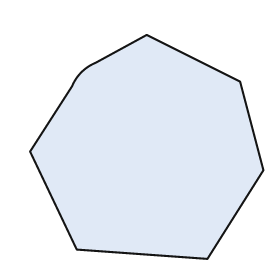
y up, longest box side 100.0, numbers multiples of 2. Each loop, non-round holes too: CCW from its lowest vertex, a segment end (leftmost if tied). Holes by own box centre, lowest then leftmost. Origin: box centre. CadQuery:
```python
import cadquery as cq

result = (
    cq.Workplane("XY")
    .moveTo(26.0, -48.0)
    .lineTo(50.0, -10.0)
    .lineTo(40.0, 28.0)
    .lineTo(0.0, 48.0)
    .lineTo(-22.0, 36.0)
    .threePointArc((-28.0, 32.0), (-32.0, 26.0))
    .lineTo(-50.0, -2.0)
    .lineTo(-30.0, -44.0)
    .close()
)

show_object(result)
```